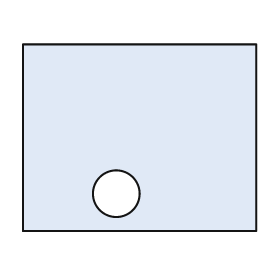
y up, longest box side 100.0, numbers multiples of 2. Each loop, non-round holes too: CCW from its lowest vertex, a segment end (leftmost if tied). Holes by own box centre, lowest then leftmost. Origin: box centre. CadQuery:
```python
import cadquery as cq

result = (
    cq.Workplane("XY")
    .moveTo(-50.0, -40.0)
    .lineTo(50.0, -40.0)
    .lineTo(50.0, 40.0)
    .lineTo(-50.0, 40.0)
    .close()
    .moveTo(-10.0, -24.0)
    .circle(10.0)
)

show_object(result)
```